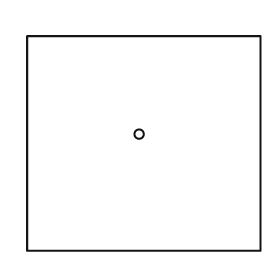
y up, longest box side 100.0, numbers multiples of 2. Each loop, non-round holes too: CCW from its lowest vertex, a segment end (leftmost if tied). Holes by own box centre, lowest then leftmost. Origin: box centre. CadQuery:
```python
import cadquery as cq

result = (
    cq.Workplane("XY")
    .moveTo(-50.0, -46.0)
    .lineTo(50.0, -46.0)
    .lineTo(50.0, 46.0)
    .lineTo(-50.0, 46.0)
    .close()
    .moveTo(-2.0, 4.0)
    .circle(2.0)
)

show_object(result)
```